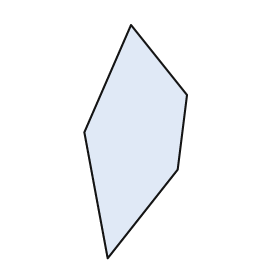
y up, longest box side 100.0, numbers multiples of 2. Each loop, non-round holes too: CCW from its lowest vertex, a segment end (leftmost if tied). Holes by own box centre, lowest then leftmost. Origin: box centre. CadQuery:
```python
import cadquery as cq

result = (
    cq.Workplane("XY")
    .moveTo(-12.0, -50.0)
    .lineTo(18.0, -12.0)
    .lineTo(22.0, 20.0)
    .lineTo(-2.0, 50.0)
    .lineTo(-22.0, 4.0)
    .close()
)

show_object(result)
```